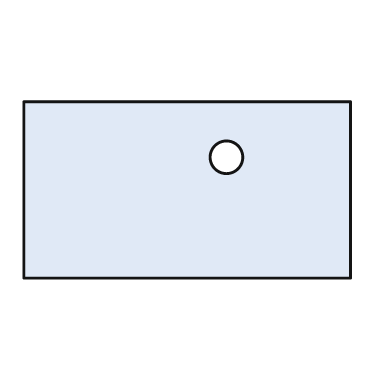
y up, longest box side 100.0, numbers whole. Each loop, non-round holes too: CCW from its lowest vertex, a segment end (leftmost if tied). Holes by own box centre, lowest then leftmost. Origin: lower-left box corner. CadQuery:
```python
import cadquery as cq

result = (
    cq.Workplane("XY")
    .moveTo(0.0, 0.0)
    .lineTo(100.0, 0.0)
    .lineTo(100.0, 54.0)
    .lineTo(0.0, 54.0)
    .close()
    .moveTo(62.0, 37.0)
    .circle(5.0)
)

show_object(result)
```